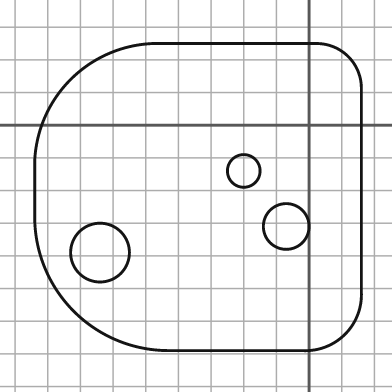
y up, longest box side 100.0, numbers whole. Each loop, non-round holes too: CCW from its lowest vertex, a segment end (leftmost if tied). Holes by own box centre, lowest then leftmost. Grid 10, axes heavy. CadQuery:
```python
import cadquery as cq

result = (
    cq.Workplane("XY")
    .moveTo(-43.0, -69.0)
    .lineTo(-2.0, -69.0)
    .threePointArc((11.0, -64.0), (16.0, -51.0))
    .lineTo(16.0, 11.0)
    .threePointArc((12.0, 21.0), (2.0, 25.0))
    .lineTo(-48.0, 25.0)
    .threePointArc((-73.0, 14.0), (-84.0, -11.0))
    .lineTo(-84.0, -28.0)
    .threePointArc((-72.0, -57.0), (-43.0, -69.0))
    .close()
    .moveTo(-64.0, -39.0)
    .circle(9.0)
    .moveTo(-7.0, -31.0)
    .circle(7.0)
    .moveTo(-20.0, -14.0)
    .circle(5.0)
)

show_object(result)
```